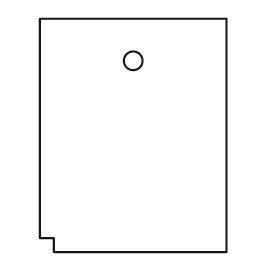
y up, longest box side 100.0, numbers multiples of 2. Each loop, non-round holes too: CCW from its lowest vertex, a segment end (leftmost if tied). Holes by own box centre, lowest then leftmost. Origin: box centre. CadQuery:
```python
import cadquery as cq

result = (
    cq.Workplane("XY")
    .moveTo(-34.0, -50.0)
    .lineTo(40.0, -50.0)
    .lineTo(40.0, 50.0)
    .lineTo(-40.0, 50.0)
    .lineTo(-40.0, -44.0)
    .lineTo(-34.0, -44.0)
    .close()
    .moveTo(0.0, 32.0)
    .circle(4.0)
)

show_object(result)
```